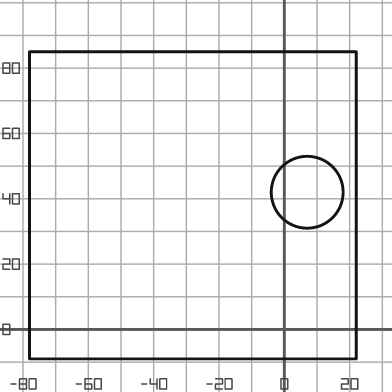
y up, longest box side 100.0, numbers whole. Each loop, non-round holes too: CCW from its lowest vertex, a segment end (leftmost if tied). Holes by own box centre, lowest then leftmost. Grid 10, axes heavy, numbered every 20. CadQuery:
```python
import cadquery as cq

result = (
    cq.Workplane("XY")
    .moveTo(-78.0, -9.0)
    .lineTo(22.0, -9.0)
    .lineTo(22.0, 85.0)
    .lineTo(-78.0, 85.0)
    .close()
    .moveTo(7.0, 42.0)
    .circle(11.0)
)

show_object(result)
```